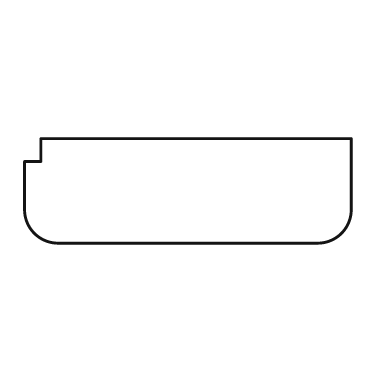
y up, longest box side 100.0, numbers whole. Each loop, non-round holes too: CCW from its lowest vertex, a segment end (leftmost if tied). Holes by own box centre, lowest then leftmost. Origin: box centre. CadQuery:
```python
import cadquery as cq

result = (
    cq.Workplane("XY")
    .moveTo(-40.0, -16.0)
    .lineTo(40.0, -16.0)
    .threePointArc((47.0, -13.0), (50.0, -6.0))
    .lineTo(50.0, 16.0)
    .lineTo(-45.0, 16.0)
    .lineTo(-45.0, 9.0)
    .lineTo(-50.0, 9.0)
    .lineTo(-50.0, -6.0)
    .threePointArc((-47.0, -13.0), (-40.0, -16.0))
    .close()
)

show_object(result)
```